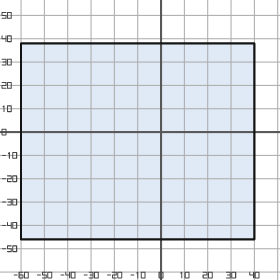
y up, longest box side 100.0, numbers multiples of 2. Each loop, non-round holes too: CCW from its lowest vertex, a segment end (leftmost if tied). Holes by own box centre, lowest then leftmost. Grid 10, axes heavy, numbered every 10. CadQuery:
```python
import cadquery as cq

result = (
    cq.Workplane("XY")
    .moveTo(-60.0, -46.0)
    .lineTo(40.0, -46.0)
    .lineTo(40.0, 38.0)
    .lineTo(-60.0, 38.0)
    .close()
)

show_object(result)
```